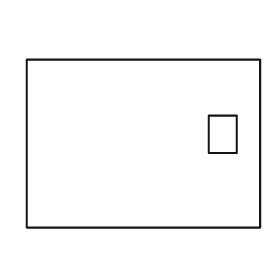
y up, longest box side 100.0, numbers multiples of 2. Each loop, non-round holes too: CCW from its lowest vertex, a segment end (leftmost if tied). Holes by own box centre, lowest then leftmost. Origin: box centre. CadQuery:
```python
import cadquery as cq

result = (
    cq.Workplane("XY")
    .moveTo(-50.0, -36.0)
    .lineTo(50.0, -36.0)
    .lineTo(50.0, 36.0)
    .lineTo(-50.0, 36.0)
    .close()
    .moveTo(28.0, -4.0)
    .lineTo(40.0, -4.0)
    .lineTo(40.0, 12.0)
    .lineTo(28.0, 12.0)
    .close()
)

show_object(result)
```